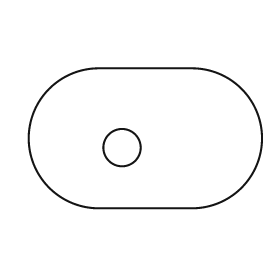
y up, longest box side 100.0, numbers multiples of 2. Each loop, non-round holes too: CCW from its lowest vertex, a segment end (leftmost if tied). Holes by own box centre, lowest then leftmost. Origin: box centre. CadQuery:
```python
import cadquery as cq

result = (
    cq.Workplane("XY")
    .moveTo(-20.0, -30.0)
    .lineTo(20.0, -30.0)
    .threePointArc((50.0, 0.0), (20.0, 30.0))
    .lineTo(-20.0, 30.0)
    .threePointArc((-50.0, 0.0), (-20.0, -30.0))
    .close()
    .moveTo(-10.0, -4.0)
    .circle(8.0)
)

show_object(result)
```